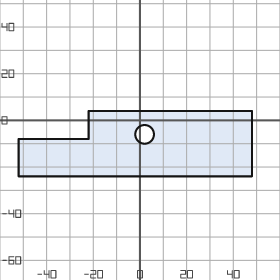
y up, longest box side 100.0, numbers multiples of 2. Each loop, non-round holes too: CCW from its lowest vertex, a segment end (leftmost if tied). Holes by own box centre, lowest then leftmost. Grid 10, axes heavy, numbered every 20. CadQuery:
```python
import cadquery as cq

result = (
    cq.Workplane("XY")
    .moveTo(-52.0, -24.0)
    .lineTo(48.0, -24.0)
    .lineTo(48.0, 4.0)
    .lineTo(-22.0, 4.0)
    .lineTo(-22.0, -8.0)
    .lineTo(-52.0, -8.0)
    .close()
    .moveTo(2.0, -6.0)
    .circle(4.0)
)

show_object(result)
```